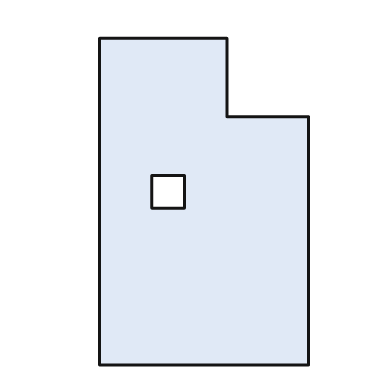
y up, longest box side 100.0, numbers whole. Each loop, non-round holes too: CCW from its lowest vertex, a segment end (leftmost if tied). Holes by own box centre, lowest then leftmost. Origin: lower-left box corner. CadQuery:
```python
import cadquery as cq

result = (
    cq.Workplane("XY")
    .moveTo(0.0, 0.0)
    .lineTo(64.0, 0.0)
    .lineTo(64.0, 76.0)
    .lineTo(39.0, 76.0)
    .lineTo(39.0, 100.0)
    .lineTo(0.0, 100.0)
    .close()
    .moveTo(16.0, 48.0)
    .lineTo(26.0, 48.0)
    .lineTo(26.0, 58.0)
    .lineTo(16.0, 58.0)
    .close()
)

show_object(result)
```